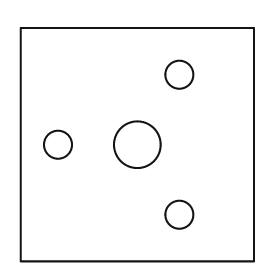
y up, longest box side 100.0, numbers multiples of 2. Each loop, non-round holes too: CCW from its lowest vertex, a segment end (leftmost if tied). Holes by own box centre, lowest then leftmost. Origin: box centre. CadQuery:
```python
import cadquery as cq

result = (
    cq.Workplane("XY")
    .moveTo(-50.0, -50.0)
    .lineTo(50.0, -50.0)
    .lineTo(50.0, 50.0)
    .lineTo(-50.0, 50.0)
    .close()
    .moveTo(18.0, -30.0)
    .circle(6.0)
    .moveTo(-34.0, 0.0)
    .circle(6.0)
    .moveTo(0.0, 0.0)
    .circle(10.0)
    .moveTo(18.0, 30.0)
    .circle(6.0)
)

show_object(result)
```